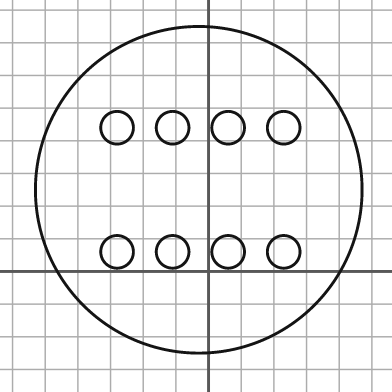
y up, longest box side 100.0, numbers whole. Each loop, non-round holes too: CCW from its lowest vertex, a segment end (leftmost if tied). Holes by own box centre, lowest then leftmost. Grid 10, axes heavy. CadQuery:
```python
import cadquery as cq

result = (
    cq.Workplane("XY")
    .moveTo(-3.0, 25.0)
    .circle(50.0)
    .moveTo(-28.0, 6.0)
    .circle(5.0)
    .moveTo(-11.0, 6.0)
    .circle(5.0)
    .moveTo(6.0, 6.0)
    .circle(5.0)
    .moveTo(23.0, 6.0)
    .circle(5.0)
    .moveTo(-28.0, 44.0)
    .circle(5.0)
    .moveTo(-11.0, 44.0)
    .circle(5.0)
    .moveTo(6.0, 44.0)
    .circle(5.0)
    .moveTo(23.0, 44.0)
    .circle(5.0)
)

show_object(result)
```